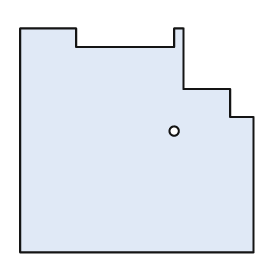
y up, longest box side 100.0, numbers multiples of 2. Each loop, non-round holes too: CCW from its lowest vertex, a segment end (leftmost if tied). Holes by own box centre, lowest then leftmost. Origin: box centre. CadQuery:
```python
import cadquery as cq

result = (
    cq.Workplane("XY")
    .moveTo(-50.0, -48.0)
    .lineTo(50.0, -48.0)
    .lineTo(50.0, 10.0)
    .lineTo(40.0, 10.0)
    .lineTo(40.0, 22.0)
    .lineTo(20.0, 22.0)
    .lineTo(20.0, 48.0)
    .lineTo(16.0, 48.0)
    .lineTo(16.0, 40.0)
    .lineTo(-26.0, 40.0)
    .lineTo(-26.0, 48.0)
    .lineTo(-50.0, 48.0)
    .close()
    .moveTo(16.0, 4.0)
    .circle(2.0)
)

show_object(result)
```